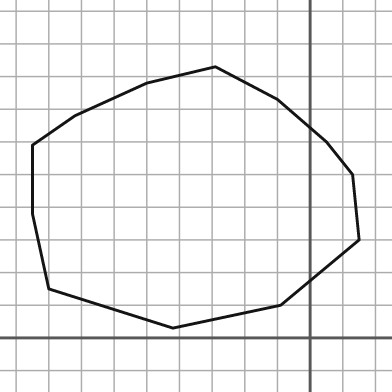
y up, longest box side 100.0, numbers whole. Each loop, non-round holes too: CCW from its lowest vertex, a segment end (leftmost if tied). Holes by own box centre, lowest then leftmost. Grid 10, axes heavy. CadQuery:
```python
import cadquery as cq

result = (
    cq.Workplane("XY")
    .moveTo(-42.0, 3.0)
    .lineTo(-9.0, 10.0)
    .lineTo(15.0, 30.0)
    .lineTo(13.0, 50.0)
    .lineTo(5.0, 60.0)
    .lineTo(-10.0, 73.0)
    .lineTo(-29.0, 83.0)
    .lineTo(-50.0, 78.0)
    .lineTo(-72.0, 68.0)
    .lineTo(-85.0, 59.0)
    .lineTo(-85.0, 38.0)
    .lineTo(-80.0, 15.0)
    .close()
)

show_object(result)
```